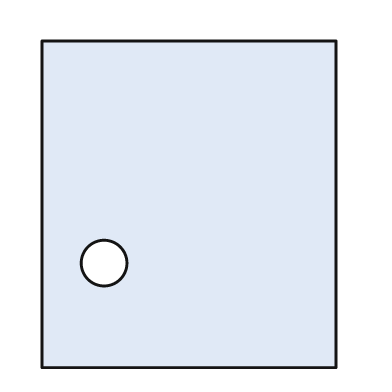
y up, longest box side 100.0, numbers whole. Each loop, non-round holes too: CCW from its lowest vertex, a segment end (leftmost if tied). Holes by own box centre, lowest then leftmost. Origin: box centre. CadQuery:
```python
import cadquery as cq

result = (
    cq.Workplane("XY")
    .moveTo(-45.0, -50.0)
    .lineTo(45.0, -50.0)
    .lineTo(45.0, 50.0)
    .lineTo(-45.0, 50.0)
    .close()
    .moveTo(-26.0, -18.0)
    .circle(7.0)
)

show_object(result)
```